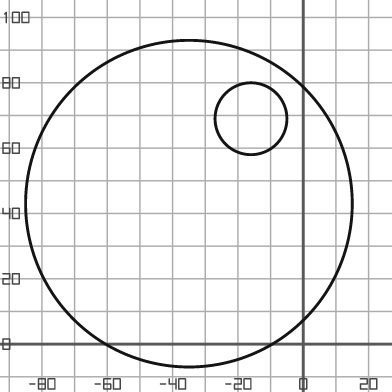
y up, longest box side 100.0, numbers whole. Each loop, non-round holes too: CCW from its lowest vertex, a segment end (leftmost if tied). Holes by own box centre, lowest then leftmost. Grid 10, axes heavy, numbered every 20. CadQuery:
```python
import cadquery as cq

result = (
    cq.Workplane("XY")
    .moveTo(-35.0, 43.0)
    .circle(50.0)
    .moveTo(-16.0, 69.0)
    .circle(11.0)
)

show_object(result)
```